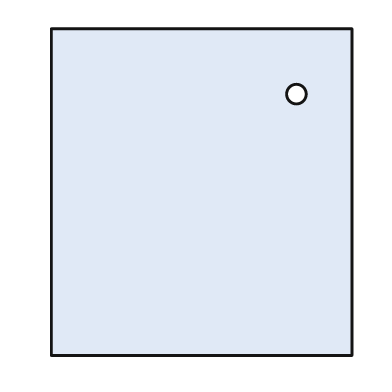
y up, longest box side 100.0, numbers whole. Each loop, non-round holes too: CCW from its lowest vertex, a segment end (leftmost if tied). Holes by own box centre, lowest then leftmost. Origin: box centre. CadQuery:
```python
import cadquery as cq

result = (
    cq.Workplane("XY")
    .moveTo(-46.0, -50.0)
    .lineTo(46.0, -50.0)
    .lineTo(46.0, 50.0)
    .lineTo(-46.0, 50.0)
    .close()
    .moveTo(29.0, 30.0)
    .circle(3.0)
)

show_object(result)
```